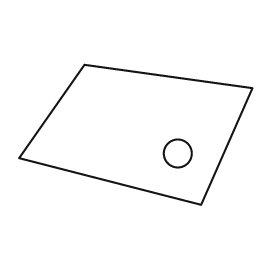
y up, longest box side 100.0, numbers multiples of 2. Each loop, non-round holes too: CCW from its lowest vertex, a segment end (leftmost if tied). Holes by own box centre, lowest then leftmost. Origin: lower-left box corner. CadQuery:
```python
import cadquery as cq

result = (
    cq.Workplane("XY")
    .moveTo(78.0, 0.0)
    .lineTo(100.0, 50.0)
    .lineTo(28.0, 60.0)
    .lineTo(0.0, 20.0)
    .close()
    .moveTo(68.0, 22.0)
    .circle(6.0)
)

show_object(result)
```